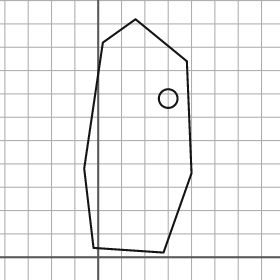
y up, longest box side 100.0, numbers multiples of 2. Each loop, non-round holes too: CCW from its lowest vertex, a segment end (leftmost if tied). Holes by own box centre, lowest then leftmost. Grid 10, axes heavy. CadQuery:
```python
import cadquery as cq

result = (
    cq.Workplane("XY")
    .moveTo(28.0, 2.0)
    .lineTo(40.0, 36.0)
    .lineTo(38.0, 84.0)
    .lineTo(16.0, 102.0)
    .lineTo(2.0, 92.0)
    .lineTo(-6.0, 38.0)
    .lineTo(-2.0, 4.0)
    .close()
    .moveTo(30.0, 68.0)
    .circle(4.0)
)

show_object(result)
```